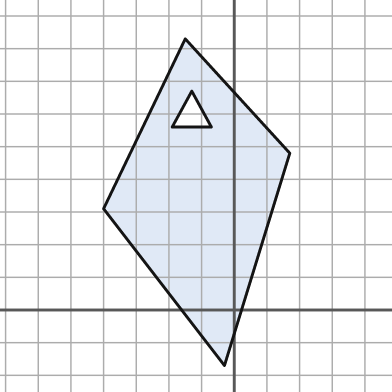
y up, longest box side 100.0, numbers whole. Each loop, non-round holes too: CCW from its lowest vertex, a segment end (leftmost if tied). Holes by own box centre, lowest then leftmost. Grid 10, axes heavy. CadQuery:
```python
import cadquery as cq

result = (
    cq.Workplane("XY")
    .moveTo(-3.0, -17.0)
    .lineTo(17.0, 48.0)
    .lineTo(-15.0, 83.0)
    .lineTo(-40.0, 31.0)
    .close()
    .moveTo(-19.0, 56.0)
    .lineTo(-7.0, 56.0)
    .lineTo(-13.0, 67.0)
    .close()
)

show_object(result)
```